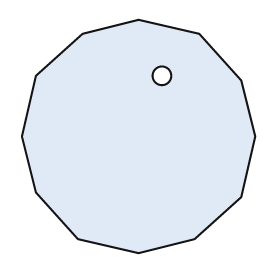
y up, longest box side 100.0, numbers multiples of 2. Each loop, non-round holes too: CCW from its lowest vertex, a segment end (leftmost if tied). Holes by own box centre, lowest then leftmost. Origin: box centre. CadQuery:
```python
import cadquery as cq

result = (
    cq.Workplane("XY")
    .moveTo(0.0, -50.0)
    .lineTo(24.0, -44.0)
    .lineTo(44.0, -26.0)
    .lineTo(50.0, 0.0)
    .lineTo(44.0, 24.0)
    .lineTo(26.0, 44.0)
    .lineTo(0.0, 50.0)
    .lineTo(-24.0, 44.0)
    .lineTo(-44.0, 26.0)
    .lineTo(-50.0, 0.0)
    .lineTo(-44.0, -24.0)
    .lineTo(-26.0, -44.0)
    .close()
    .moveTo(10.0, 26.0)
    .circle(4.0)
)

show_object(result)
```